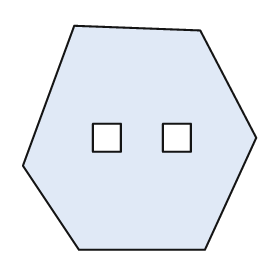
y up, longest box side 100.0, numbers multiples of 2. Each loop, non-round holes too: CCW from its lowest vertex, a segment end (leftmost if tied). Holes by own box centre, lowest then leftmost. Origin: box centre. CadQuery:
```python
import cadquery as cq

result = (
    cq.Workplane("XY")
    .moveTo(-26.0, -48.0)
    .lineTo(28.0, -48.0)
    .lineTo(50.0, 0.0)
    .lineTo(26.0, 46.0)
    .lineTo(-28.0, 48.0)
    .lineTo(-50.0, -12.0)
    .close()
    .moveTo(-20.0, -6.0)
    .lineTo(-8.0, -6.0)
    .lineTo(-8.0, 6.0)
    .lineTo(-20.0, 6.0)
    .close()
    .moveTo(10.0, -6.0)
    .lineTo(22.0, -6.0)
    .lineTo(22.0, 6.0)
    .lineTo(10.0, 6.0)
    .close()
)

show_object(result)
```